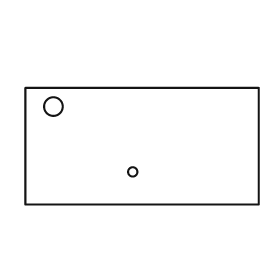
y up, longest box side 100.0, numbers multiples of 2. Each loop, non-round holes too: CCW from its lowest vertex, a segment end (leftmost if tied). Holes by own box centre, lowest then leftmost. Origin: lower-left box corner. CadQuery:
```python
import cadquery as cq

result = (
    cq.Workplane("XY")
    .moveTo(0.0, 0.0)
    .lineTo(100.0, 0.0)
    .lineTo(100.0, 50.0)
    .lineTo(0.0, 50.0)
    .close()
    .moveTo(46.0, 14.0)
    .circle(2.0)
    .moveTo(12.0, 42.0)
    .circle(4.0)
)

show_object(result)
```